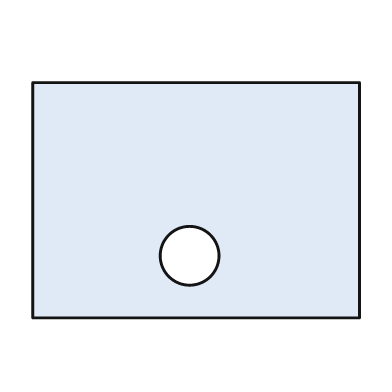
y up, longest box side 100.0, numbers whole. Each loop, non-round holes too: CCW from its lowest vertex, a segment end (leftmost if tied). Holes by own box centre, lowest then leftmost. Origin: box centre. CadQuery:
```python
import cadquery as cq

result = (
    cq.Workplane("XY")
    .moveTo(-50.0, -36.0)
    .lineTo(50.0, -36.0)
    .lineTo(50.0, 36.0)
    .lineTo(-50.0, 36.0)
    .close()
    .moveTo(-2.0, -17.0)
    .circle(9.0)
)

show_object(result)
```